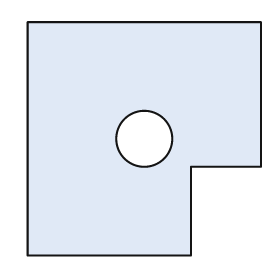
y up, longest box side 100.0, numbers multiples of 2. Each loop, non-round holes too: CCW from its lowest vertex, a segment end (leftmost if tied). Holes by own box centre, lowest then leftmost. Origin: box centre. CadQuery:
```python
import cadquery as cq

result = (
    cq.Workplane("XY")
    .moveTo(-50.0, -50.0)
    .lineTo(20.0, -50.0)
    .lineTo(20.0, -12.0)
    .lineTo(50.0, -12.0)
    .lineTo(50.0, 50.0)
    .lineTo(-50.0, 50.0)
    .close()
    .moveTo(0.0, 0.0)
    .circle(12.0)
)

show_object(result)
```